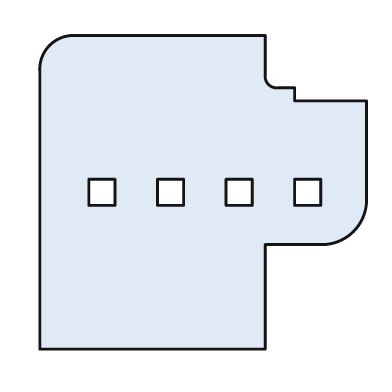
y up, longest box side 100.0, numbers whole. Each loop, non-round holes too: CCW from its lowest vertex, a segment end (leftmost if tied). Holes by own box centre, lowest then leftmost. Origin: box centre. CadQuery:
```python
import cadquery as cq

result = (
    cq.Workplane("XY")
    .moveTo(-50.0, -48.0)
    .lineTo(19.0, -48.0)
    .lineTo(19.0, -16.0)
    .lineTo(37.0, -16.0)
    .threePointArc((46.0, -12.0), (50.0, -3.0))
    .lineTo(50.0, 28.0)
    .lineTo(28.0, 28.0)
    .lineTo(28.0, 32.0)
    .lineTo(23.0, 32.0)
    .threePointArc((20.0, 33.0), (19.0, 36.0))
    .lineTo(19.0, 48.0)
    .lineTo(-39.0, 48.0)
    .threePointArc((-47.0, 45.0), (-50.0, 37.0))
    .close()
    .moveTo(-35.0, -4.0)
    .lineTo(-27.0, -4.0)
    .lineTo(-27.0, 4.0)
    .lineTo(-35.0, 4.0)
    .close()
    .moveTo(-14.0, -4.0)
    .lineTo(-6.0, -4.0)
    .lineTo(-6.0, 4.0)
    .lineTo(-14.0, 4.0)
    .close()
    .moveTo(7.0, -4.0)
    .lineTo(15.0, -4.0)
    .lineTo(15.0, 4.0)
    .lineTo(7.0, 4.0)
    .close()
    .moveTo(28.0, -4.0)
    .lineTo(36.0, -4.0)
    .lineTo(36.0, 4.0)
    .lineTo(28.0, 4.0)
    .close()
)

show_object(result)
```